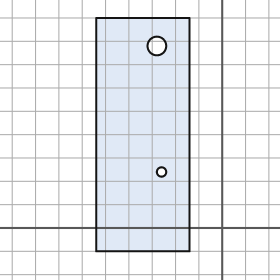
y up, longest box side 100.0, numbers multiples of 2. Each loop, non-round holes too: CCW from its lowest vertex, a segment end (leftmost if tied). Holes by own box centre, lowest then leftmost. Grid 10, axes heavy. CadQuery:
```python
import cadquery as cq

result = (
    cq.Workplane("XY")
    .moveTo(-54.0, -10.0)
    .lineTo(-14.0, -10.0)
    .lineTo(-14.0, 90.0)
    .lineTo(-54.0, 90.0)
    .close()
    .moveTo(-26.0, 24.0)
    .circle(2.0)
    .moveTo(-28.0, 78.0)
    .circle(4.0)
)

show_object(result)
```